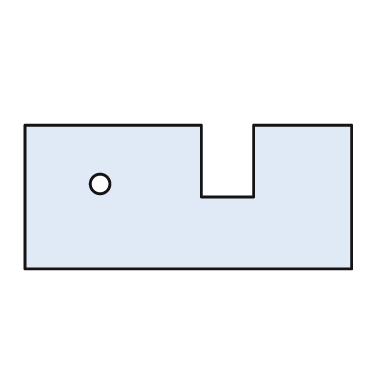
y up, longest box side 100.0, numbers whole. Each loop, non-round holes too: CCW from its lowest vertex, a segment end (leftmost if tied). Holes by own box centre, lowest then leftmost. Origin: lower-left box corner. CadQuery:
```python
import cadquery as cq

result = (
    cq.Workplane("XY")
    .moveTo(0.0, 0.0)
    .lineTo(100.0, 0.0)
    .lineTo(100.0, 44.0)
    .lineTo(70.0, 44.0)
    .lineTo(70.0, 22.0)
    .lineTo(54.0, 22.0)
    .lineTo(54.0, 44.0)
    .lineTo(0.0, 44.0)
    .close()
    .moveTo(23.0, 26.0)
    .circle(3.0)
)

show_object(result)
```